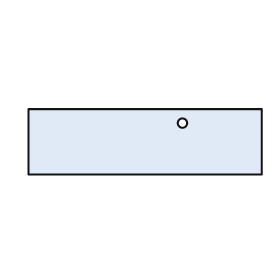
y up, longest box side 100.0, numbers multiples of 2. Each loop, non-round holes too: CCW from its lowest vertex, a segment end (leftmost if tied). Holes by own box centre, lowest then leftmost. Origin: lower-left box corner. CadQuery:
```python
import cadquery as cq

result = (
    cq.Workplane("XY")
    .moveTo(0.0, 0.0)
    .lineTo(100.0, 0.0)
    .lineTo(100.0, 28.0)
    .lineTo(0.0, 28.0)
    .close()
    .moveTo(66.0, 22.0)
    .circle(2.0)
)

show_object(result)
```